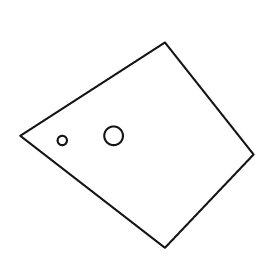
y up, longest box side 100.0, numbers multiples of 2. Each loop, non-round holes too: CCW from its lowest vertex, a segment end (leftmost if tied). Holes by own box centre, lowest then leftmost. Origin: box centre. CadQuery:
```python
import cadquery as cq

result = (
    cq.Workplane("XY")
    .moveTo(12.0, -44.0)
    .lineTo(50.0, -4.0)
    .lineTo(12.0, 44.0)
    .lineTo(-50.0, 4.0)
    .close()
    .moveTo(-32.0, 2.0)
    .circle(2.0)
    .moveTo(-10.0, 4.0)
    .circle(4.0)
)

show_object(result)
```